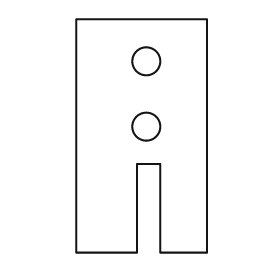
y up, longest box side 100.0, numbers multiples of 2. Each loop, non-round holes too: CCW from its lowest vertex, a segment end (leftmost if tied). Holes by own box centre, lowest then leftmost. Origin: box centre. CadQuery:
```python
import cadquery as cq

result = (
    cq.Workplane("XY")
    .moveTo(-28.0, -50.0)
    .lineTo(-2.0, -50.0)
    .lineTo(-2.0, -12.0)
    .lineTo(8.0, -12.0)
    .lineTo(8.0, -50.0)
    .lineTo(28.0, -50.0)
    .lineTo(28.0, 50.0)
    .lineTo(-28.0, 50.0)
    .close()
    .moveTo(2.0, 4.0)
    .circle(6.0)
    .moveTo(2.0, 32.0)
    .circle(6.0)
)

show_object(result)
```